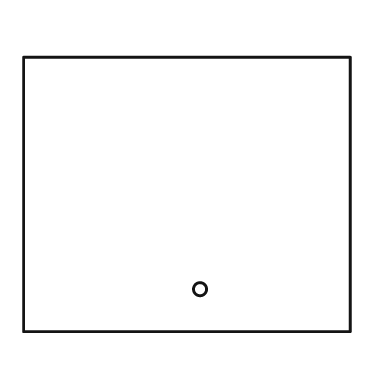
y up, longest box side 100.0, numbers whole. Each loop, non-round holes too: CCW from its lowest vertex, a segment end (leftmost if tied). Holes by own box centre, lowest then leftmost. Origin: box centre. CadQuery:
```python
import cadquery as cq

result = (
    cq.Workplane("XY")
    .moveTo(-50.0, -42.0)
    .lineTo(50.0, -42.0)
    .lineTo(50.0, 42.0)
    .lineTo(-50.0, 42.0)
    .close()
    .moveTo(4.0, -29.0)
    .circle(2.0)
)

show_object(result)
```